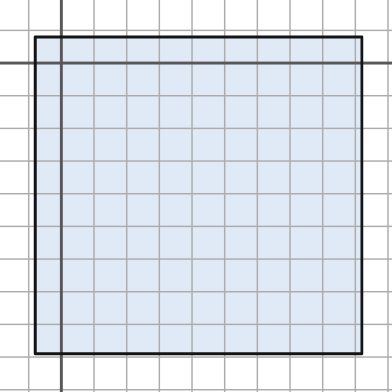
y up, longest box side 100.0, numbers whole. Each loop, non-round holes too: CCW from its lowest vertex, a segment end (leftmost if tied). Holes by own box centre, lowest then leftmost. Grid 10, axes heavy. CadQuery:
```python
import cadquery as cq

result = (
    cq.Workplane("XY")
    .moveTo(-8.0, -89.0)
    .lineTo(92.0, -89.0)
    .lineTo(92.0, 8.0)
    .lineTo(-8.0, 8.0)
    .close()
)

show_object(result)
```